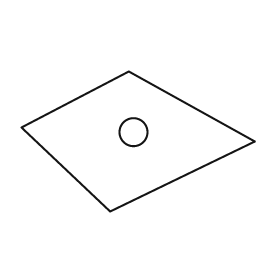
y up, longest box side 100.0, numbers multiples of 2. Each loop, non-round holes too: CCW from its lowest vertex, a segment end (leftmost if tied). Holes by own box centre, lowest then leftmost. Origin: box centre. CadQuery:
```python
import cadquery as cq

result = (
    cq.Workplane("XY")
    .moveTo(-12.0, -30.0)
    .lineTo(50.0, 0.0)
    .lineTo(-4.0, 30.0)
    .lineTo(-50.0, 6.0)
    .close()
    .moveTo(-2.0, 4.0)
    .circle(6.0)
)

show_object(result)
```